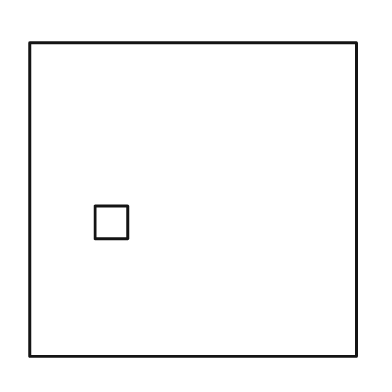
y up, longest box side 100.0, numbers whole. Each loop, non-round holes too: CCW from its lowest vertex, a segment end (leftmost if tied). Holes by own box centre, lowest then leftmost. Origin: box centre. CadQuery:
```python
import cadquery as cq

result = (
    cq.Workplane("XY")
    .moveTo(-50.0, -48.0)
    .lineTo(50.0, -48.0)
    .lineTo(50.0, 48.0)
    .lineTo(-50.0, 48.0)
    .close()
    .moveTo(-30.0, -12.0)
    .lineTo(-20.0, -12.0)
    .lineTo(-20.0, -2.0)
    .lineTo(-30.0, -2.0)
    .close()
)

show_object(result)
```